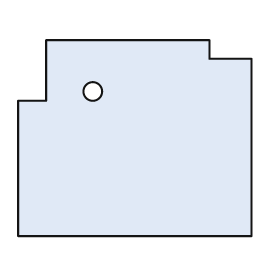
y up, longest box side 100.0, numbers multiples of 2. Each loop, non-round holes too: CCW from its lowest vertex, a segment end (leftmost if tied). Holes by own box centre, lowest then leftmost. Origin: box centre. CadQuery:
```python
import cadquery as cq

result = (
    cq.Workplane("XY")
    .moveTo(-50.0, -42.0)
    .lineTo(50.0, -42.0)
    .lineTo(50.0, 34.0)
    .lineTo(32.0, 34.0)
    .lineTo(32.0, 42.0)
    .lineTo(-38.0, 42.0)
    .lineTo(-38.0, 16.0)
    .lineTo(-50.0, 16.0)
    .close()
    .moveTo(-18.0, 20.0)
    .circle(4.0)
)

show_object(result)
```